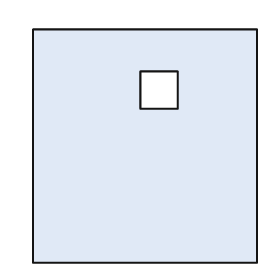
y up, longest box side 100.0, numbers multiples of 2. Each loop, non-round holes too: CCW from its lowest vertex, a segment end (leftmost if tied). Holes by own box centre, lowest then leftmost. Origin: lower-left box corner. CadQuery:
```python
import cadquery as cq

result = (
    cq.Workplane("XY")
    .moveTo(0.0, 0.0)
    .lineTo(96.0, 0.0)
    .lineTo(96.0, 100.0)
    .lineTo(0.0, 100.0)
    .close()
    .moveTo(46.0, 66.0)
    .lineTo(62.0, 66.0)
    .lineTo(62.0, 82.0)
    .lineTo(46.0, 82.0)
    .close()
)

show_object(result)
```